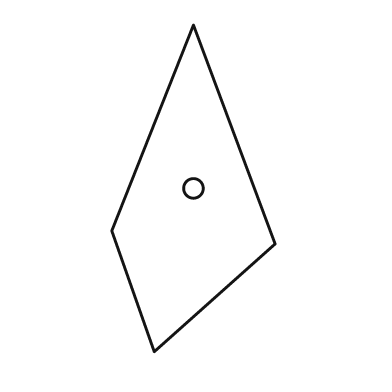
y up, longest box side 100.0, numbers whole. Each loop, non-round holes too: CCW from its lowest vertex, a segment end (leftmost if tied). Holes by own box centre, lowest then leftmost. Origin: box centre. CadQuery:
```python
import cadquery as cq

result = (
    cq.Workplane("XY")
    .moveTo(-12.0, -50.0)
    .lineTo(25.0, -17.0)
    .lineTo(0.0, 50.0)
    .lineTo(-25.0, -13.0)
    .close()
    .moveTo(0.0, 0.0)
    .circle(3.0)
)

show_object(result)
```